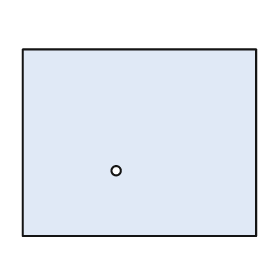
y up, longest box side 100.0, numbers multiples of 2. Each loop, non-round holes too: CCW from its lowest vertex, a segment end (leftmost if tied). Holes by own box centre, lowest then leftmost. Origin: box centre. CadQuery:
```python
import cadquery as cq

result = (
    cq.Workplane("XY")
    .moveTo(-50.0, -40.0)
    .lineTo(50.0, -40.0)
    .lineTo(50.0, 40.0)
    .lineTo(-50.0, 40.0)
    .close()
    .moveTo(-10.0, -12.0)
    .circle(2.0)
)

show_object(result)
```